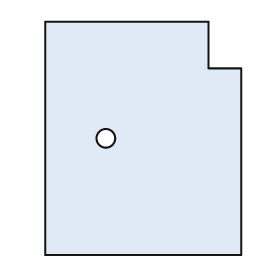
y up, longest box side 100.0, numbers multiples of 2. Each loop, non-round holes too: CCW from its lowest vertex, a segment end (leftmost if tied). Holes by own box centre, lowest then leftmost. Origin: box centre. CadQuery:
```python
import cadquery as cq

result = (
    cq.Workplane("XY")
    .moveTo(-42.0, -50.0)
    .lineTo(42.0, -50.0)
    .lineTo(42.0, 30.0)
    .lineTo(28.0, 30.0)
    .lineTo(28.0, 50.0)
    .lineTo(-42.0, 50.0)
    .close()
    .moveTo(-16.0, 0.0)
    .circle(4.0)
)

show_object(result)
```